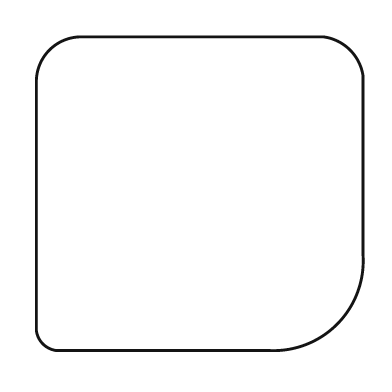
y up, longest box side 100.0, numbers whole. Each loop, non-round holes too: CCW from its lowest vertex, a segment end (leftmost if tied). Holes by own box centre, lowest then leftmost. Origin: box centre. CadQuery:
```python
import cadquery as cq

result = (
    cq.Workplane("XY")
    .moveTo(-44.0, -48.0)
    .lineTo(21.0, -48.0)
    .threePointArc((42.0, -40.0), (50.0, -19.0))
    .lineTo(50.0, 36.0)
    .threePointArc((46.0, 44.0), (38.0, 48.0))
    .lineTo(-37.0, 48.0)
    .threePointArc((-46.0, 44.0), (-50.0, 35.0))
    .lineTo(-50.0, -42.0)
    .threePointArc((-48.0, -46.0), (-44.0, -48.0))
    .close()
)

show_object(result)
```